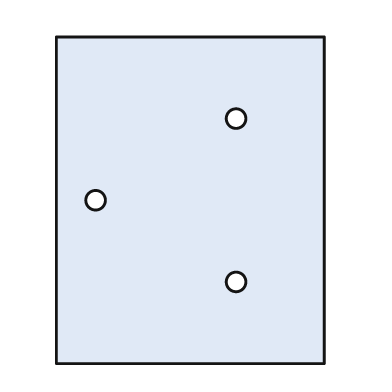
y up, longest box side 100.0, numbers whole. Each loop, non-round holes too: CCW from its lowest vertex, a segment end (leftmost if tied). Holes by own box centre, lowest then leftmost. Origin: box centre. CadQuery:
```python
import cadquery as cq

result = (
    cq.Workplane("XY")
    .moveTo(-41.0, -50.0)
    .lineTo(41.0, -50.0)
    .lineTo(41.0, 50.0)
    .lineTo(-41.0, 50.0)
    .close()
    .moveTo(14.0, -25.0)
    .circle(3.0)
    .moveTo(-29.0, 0.0)
    .circle(3.0)
    .moveTo(14.0, 25.0)
    .circle(3.0)
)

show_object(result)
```